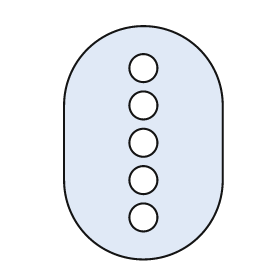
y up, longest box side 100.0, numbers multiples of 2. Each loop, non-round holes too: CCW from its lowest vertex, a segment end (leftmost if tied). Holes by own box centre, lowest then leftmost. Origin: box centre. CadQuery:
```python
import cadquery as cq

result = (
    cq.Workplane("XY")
    .moveTo(-34.0, -16.0)
    .threePointArc((0.0, -50.0), (34.0, -16.0))
    .lineTo(34.0, 16.0)
    .threePointArc((0.0, 50.0), (-34.0, 16.0))
    .close()
    .moveTo(0.0, -32.0)
    .circle(6.0)
    .moveTo(0.0, -16.0)
    .circle(6.0)
    .moveTo(0.0, 0.0)
    .circle(6.0)
    .moveTo(0.0, 16.0)
    .circle(6.0)
    .moveTo(0.0, 32.0)
    .circle(6.0)
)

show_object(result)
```